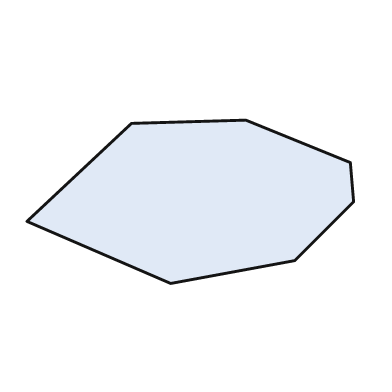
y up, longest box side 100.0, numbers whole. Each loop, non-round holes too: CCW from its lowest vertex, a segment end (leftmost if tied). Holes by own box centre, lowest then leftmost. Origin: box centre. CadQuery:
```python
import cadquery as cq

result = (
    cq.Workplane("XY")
    .moveTo(-6.0, -25.0)
    .lineTo(32.0, -18.0)
    .lineTo(50.0, 0.0)
    .lineTo(49.0, 12.0)
    .lineTo(17.0, 25.0)
    .lineTo(-18.0, 24.0)
    .lineTo(-50.0, -6.0)
    .close()
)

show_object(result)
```